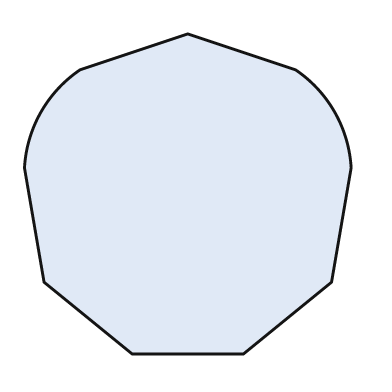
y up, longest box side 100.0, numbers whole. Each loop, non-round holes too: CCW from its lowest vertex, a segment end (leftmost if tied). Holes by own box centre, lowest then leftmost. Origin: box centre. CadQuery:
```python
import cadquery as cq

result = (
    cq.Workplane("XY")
    .moveTo(-17.0, -49.0)
    .lineTo(17.0, -49.0)
    .lineTo(44.0, -27.0)
    .lineTo(50.0, 8.0)
    .threePointArc((45.0, 25.0), (33.0, 38.0))
    .lineTo(0.0, 49.0)
    .lineTo(-33.0, 38.0)
    .threePointArc((-45.0, 25.0), (-50.0, 8.0))
    .lineTo(-44.0, -27.0)
    .close()
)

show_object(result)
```